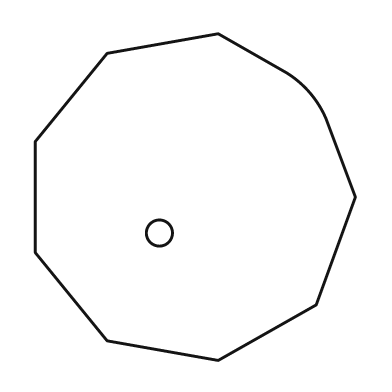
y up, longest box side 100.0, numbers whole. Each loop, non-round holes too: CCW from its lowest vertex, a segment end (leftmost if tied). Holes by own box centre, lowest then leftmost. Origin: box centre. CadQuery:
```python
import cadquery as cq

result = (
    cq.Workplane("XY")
    .moveTo(7.0, -50.0)
    .lineTo(37.0, -33.0)
    .lineTo(49.0, 0.0)
    .lineTo(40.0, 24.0)
    .threePointArc((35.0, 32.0), (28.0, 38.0))
    .lineTo(7.0, 50.0)
    .lineTo(-27.0, 44.0)
    .lineTo(-49.0, 17.0)
    .lineTo(-49.0, -17.0)
    .lineTo(-27.0, -44.0)
    .close()
    .moveTo(-11.0, -11.0)
    .circle(4.0)
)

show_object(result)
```